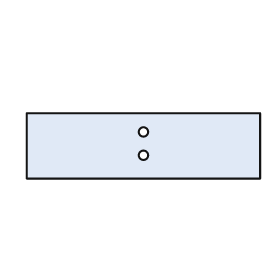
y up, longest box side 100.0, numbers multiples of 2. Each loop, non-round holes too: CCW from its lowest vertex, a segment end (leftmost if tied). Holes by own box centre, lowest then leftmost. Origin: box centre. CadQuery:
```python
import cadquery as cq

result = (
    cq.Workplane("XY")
    .moveTo(-50.0, -14.0)
    .lineTo(50.0, -14.0)
    .lineTo(50.0, 14.0)
    .lineTo(-50.0, 14.0)
    .close()
    .moveTo(0.0, -4.0)
    .circle(2.0)
    .moveTo(0.0, 6.0)
    .circle(2.0)
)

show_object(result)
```